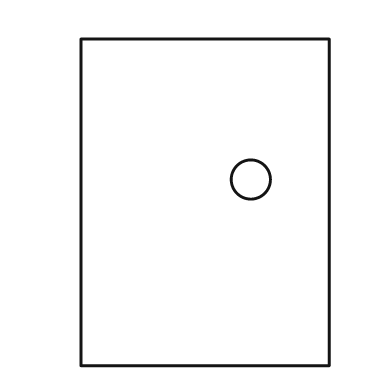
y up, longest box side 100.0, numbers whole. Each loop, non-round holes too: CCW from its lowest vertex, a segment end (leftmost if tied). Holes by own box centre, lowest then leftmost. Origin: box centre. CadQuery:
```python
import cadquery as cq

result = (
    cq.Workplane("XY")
    .moveTo(-38.0, -50.0)
    .lineTo(38.0, -50.0)
    .lineTo(38.0, 50.0)
    .lineTo(-38.0, 50.0)
    .close()
    .moveTo(14.0, 7.0)
    .circle(6.0)
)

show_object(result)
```